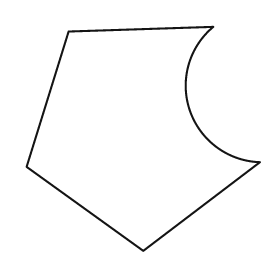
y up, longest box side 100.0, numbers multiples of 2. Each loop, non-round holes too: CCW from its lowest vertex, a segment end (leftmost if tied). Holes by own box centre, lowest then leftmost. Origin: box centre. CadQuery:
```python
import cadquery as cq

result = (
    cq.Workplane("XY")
    .moveTo(0.0, -48.0)
    .lineTo(50.0, -10.0)
    .threePointArc((20.0, 12.0), (30.0, 48.0))
    .lineTo(-32.0, 46.0)
    .lineTo(-50.0, -12.0)
    .close()
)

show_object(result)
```